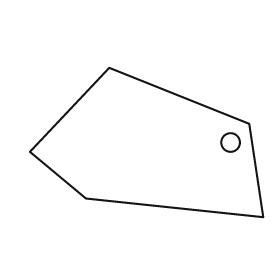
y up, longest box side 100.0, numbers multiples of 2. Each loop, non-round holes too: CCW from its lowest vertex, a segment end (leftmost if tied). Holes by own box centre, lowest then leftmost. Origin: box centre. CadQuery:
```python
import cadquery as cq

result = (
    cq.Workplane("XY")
    .moveTo(50.0, -32.0)
    .lineTo(44.0, 8.0)
    .lineTo(-16.0, 32.0)
    .lineTo(-50.0, -4.0)
    .lineTo(-26.0, -24.0)
    .close()
    .moveTo(36.0, 0.0)
    .circle(4.0)
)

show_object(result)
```